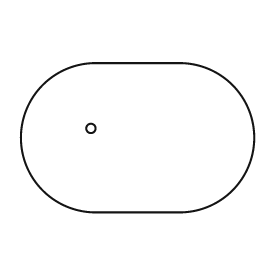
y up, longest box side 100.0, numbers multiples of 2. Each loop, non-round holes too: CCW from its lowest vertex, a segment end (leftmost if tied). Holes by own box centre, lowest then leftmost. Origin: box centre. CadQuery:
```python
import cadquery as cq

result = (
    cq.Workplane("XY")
    .moveTo(-18.0, -32.0)
    .lineTo(18.0, -32.0)
    .threePointArc((50.0, 0.0), (18.0, 32.0))
    .lineTo(-18.0, 32.0)
    .threePointArc((-50.0, 0.0), (-18.0, -32.0))
    .close()
    .moveTo(-20.0, 4.0)
    .circle(2.0)
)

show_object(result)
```